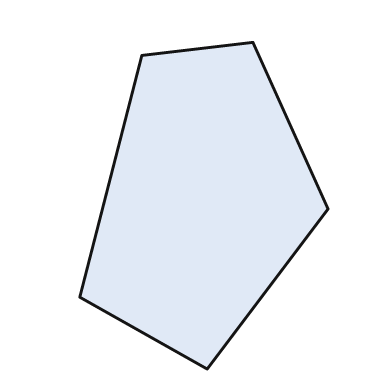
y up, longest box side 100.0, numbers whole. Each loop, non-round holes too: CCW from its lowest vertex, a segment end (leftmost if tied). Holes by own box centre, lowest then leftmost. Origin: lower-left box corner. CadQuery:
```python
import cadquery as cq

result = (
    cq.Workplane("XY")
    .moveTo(39.0, 0.0)
    .lineTo(76.0, 49.0)
    .lineTo(53.0, 100.0)
    .lineTo(19.0, 96.0)
    .lineTo(0.0, 22.0)
    .close()
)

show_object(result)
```